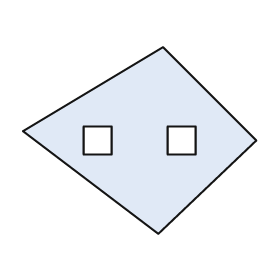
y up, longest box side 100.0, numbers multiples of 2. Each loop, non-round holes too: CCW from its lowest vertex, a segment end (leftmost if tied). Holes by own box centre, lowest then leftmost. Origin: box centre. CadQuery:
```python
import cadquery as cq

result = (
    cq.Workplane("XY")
    .moveTo(8.0, -40.0)
    .lineTo(50.0, 0.0)
    .lineTo(10.0, 40.0)
    .lineTo(-50.0, 4.0)
    .close()
    .moveTo(-24.0, -6.0)
    .lineTo(-12.0, -6.0)
    .lineTo(-12.0, 6.0)
    .lineTo(-24.0, 6.0)
    .close()
    .moveTo(12.0, -6.0)
    .lineTo(24.0, -6.0)
    .lineTo(24.0, 6.0)
    .lineTo(12.0, 6.0)
    .close()
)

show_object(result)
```